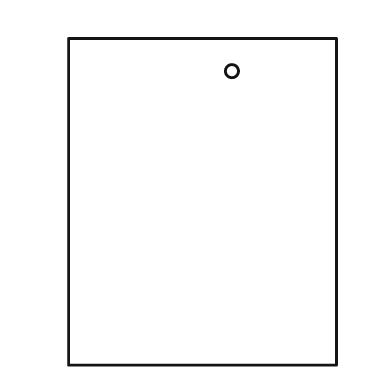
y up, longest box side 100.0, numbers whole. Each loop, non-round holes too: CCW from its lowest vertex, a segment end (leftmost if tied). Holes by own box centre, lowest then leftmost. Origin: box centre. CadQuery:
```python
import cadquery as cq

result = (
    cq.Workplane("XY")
    .moveTo(-41.0, -50.0)
    .lineTo(41.0, -50.0)
    .lineTo(41.0, 50.0)
    .lineTo(-41.0, 50.0)
    .close()
    .moveTo(9.0, 40.0)
    .circle(2.0)
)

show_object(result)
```